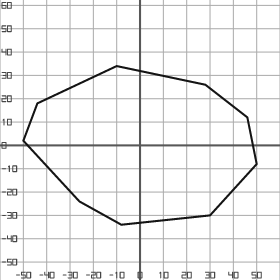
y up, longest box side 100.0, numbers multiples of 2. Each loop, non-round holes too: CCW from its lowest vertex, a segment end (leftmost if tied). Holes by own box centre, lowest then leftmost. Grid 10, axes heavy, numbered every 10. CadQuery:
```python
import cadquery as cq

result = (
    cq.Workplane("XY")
    .moveTo(-8.0, -34.0)
    .lineTo(30.0, -30.0)
    .lineTo(50.0, -8.0)
    .lineTo(46.0, 12.0)
    .lineTo(28.0, 26.0)
    .lineTo(-10.0, 34.0)
    .lineTo(-44.0, 18.0)
    .lineTo(-50.0, 2.0)
    .lineTo(-26.0, -24.0)
    .close()
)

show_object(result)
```